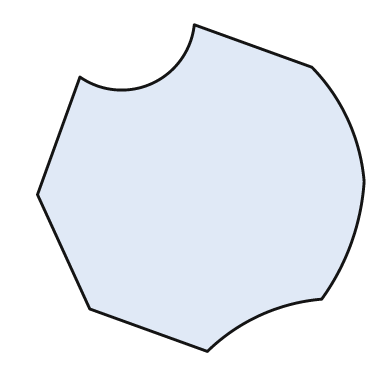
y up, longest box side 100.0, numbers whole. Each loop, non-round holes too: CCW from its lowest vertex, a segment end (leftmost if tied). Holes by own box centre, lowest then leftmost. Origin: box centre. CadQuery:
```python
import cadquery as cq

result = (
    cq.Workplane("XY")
    .moveTo(2.0, -50.0)
    .threePointArc((18.0, -39.0), (37.0, -34.0))
    .threePointArc((46.0, -17.0), (50.0, 2.0))
    .threePointArc((45.0, 21.0), (34.0, 37.0))
    .lineTo(-2.0, 50.0)
    .threePointArc((-15.0, 32.0), (-37.0, 34.0))
    .lineTo(-50.0, -2.0)
    .lineTo(-34.0, -37.0)
    .close()
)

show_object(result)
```